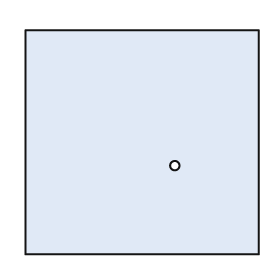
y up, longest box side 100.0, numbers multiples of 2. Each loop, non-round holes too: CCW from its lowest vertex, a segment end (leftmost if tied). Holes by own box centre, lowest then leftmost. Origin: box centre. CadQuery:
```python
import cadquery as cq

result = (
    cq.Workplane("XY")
    .moveTo(-50.0, -48.0)
    .lineTo(50.0, -48.0)
    .lineTo(50.0, 48.0)
    .lineTo(-50.0, 48.0)
    .close()
    .moveTo(14.0, -10.0)
    .circle(2.0)
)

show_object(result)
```